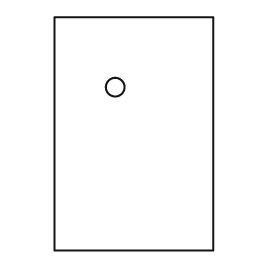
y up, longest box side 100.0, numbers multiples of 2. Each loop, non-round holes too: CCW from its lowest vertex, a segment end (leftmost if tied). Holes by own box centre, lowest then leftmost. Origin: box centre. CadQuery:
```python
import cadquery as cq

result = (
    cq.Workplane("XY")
    .moveTo(-34.0, -50.0)
    .lineTo(34.0, -50.0)
    .lineTo(34.0, 50.0)
    .lineTo(-34.0, 50.0)
    .close()
    .moveTo(-8.0, 20.0)
    .circle(4.0)
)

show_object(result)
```